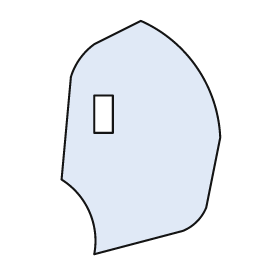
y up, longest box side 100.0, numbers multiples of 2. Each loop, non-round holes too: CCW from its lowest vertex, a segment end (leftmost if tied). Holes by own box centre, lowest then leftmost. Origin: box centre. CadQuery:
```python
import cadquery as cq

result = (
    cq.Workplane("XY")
    .moveTo(-20.0, -50.0)
    .lineTo(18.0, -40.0)
    .threePointArc((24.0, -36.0), (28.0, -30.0))
    .lineTo(34.0, 0.0)
    .threePointArc((24.0, 30.0), (0.0, 50.0))
    .lineTo(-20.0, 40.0)
    .threePointArc((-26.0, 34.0), (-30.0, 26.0))
    .lineTo(-34.0, -18.0)
    .threePointArc((-22.0, -32.0), (-20.0, -50.0))
    .close()
    .moveTo(-20.0, 2.0)
    .lineTo(-12.0, 2.0)
    .lineTo(-12.0, 18.0)
    .lineTo(-20.0, 18.0)
    .close()
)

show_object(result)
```